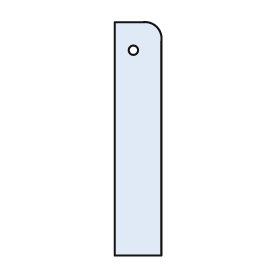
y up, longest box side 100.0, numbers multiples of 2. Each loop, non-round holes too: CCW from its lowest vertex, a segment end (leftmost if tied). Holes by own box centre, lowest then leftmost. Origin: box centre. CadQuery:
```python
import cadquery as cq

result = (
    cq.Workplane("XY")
    .moveTo(-10.0, -50.0)
    .lineTo(10.0, -50.0)
    .lineTo(10.0, 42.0)
    .threePointArc((8.0, 48.0), (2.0, 50.0))
    .lineTo(-10.0, 50.0)
    .close()
    .moveTo(-2.0, 38.0)
    .circle(2.0)
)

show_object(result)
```